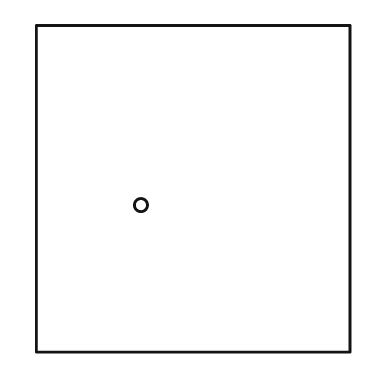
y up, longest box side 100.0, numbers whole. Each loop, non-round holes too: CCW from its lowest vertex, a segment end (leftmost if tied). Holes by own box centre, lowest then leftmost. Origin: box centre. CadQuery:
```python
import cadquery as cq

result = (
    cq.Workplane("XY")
    .moveTo(-48.0, -50.0)
    .lineTo(48.0, -50.0)
    .lineTo(48.0, 50.0)
    .lineTo(-48.0, 50.0)
    .close()
    .moveTo(-16.0, -5.0)
    .circle(2.0)
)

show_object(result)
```